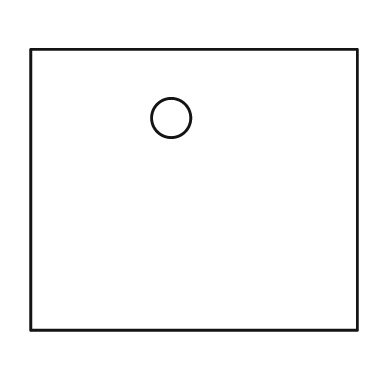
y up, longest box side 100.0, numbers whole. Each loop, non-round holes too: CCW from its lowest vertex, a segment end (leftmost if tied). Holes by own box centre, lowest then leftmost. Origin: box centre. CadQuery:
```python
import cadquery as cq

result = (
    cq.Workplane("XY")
    .moveTo(-50.0, -43.0)
    .lineTo(50.0, -43.0)
    .lineTo(50.0, 43.0)
    .lineTo(-50.0, 43.0)
    .close()
    .moveTo(-7.0, 22.0)
    .circle(6.0)
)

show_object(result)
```